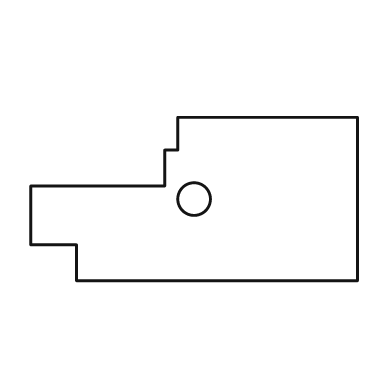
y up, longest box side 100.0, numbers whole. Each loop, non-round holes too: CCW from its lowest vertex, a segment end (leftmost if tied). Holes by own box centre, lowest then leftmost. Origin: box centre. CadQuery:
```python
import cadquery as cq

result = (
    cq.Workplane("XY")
    .moveTo(-36.0, -25.0)
    .lineTo(50.0, -25.0)
    .lineTo(50.0, 25.0)
    .lineTo(-5.0, 25.0)
    .lineTo(-5.0, 15.0)
    .lineTo(-9.0, 15.0)
    .lineTo(-9.0, 4.0)
    .lineTo(-50.0, 4.0)
    .lineTo(-50.0, -14.0)
    .lineTo(-36.0, -14.0)
    .close()
    .moveTo(0.0, 0.0)
    .circle(5.0)
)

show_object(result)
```